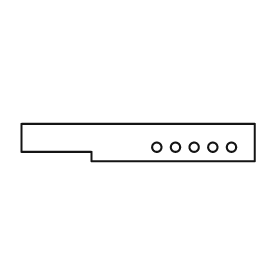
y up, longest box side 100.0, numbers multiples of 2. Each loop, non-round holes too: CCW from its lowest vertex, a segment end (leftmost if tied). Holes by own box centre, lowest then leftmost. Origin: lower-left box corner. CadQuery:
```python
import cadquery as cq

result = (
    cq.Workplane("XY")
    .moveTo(30.0, 0.0)
    .lineTo(100.0, 0.0)
    .lineTo(100.0, 16.0)
    .lineTo(0.0, 16.0)
    .lineTo(0.0, 4.0)
    .lineTo(30.0, 4.0)
    .close()
    .moveTo(58.0, 6.0)
    .circle(2.0)
    .moveTo(66.0, 6.0)
    .circle(2.0)
    .moveTo(74.0, 6.0)
    .circle(2.0)
    .moveTo(82.0, 6.0)
    .circle(2.0)
    .moveTo(90.0, 6.0)
    .circle(2.0)
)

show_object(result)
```